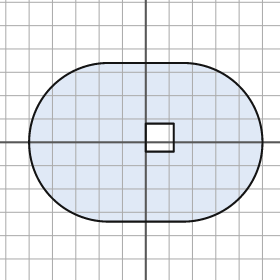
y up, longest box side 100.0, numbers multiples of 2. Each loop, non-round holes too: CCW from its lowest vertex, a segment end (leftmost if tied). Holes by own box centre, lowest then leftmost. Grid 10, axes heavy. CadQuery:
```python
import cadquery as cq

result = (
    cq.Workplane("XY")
    .moveTo(-16.0, -34.0)
    .lineTo(16.0, -34.0)
    .threePointArc((50.0, 0.0), (16.0, 34.0))
    .lineTo(-16.0, 34.0)
    .threePointArc((-50.0, 0.0), (-16.0, -34.0))
    .close()
    .moveTo(0.0, -4.0)
    .lineTo(12.0, -4.0)
    .lineTo(12.0, 8.0)
    .lineTo(0.0, 8.0)
    .close()
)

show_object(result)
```